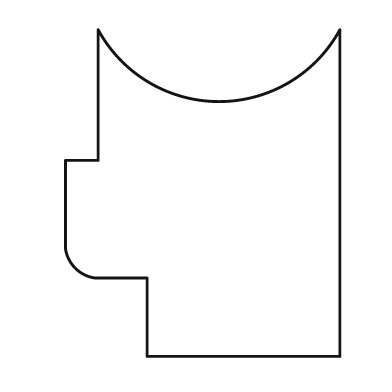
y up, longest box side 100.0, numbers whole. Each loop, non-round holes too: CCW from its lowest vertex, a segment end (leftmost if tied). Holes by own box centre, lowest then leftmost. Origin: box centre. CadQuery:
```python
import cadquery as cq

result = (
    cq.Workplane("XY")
    .moveTo(-17.0, -50.0)
    .lineTo(42.0, -50.0)
    .lineTo(42.0, 50.0)
    .threePointArc((5.0, 28.0), (-32.0, 50.0))
    .lineTo(-32.0, 10.0)
    .lineTo(-42.0, 10.0)
    .lineTo(-42.0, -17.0)
    .threePointArc((-39.0, -23.0), (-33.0, -26.0))
    .lineTo(-17.0, -26.0)
    .close()
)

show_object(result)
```